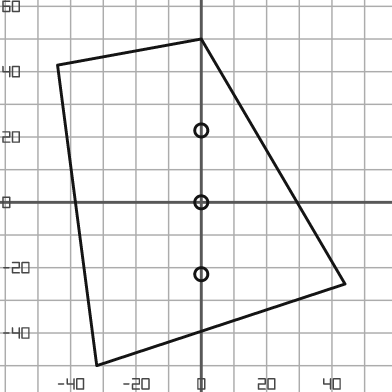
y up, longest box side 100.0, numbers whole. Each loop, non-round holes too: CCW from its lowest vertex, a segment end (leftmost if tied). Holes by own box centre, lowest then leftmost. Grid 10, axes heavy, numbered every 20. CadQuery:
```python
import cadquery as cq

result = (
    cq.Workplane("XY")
    .moveTo(-32.0, -50.0)
    .lineTo(44.0, -25.0)
    .lineTo(0.0, 50.0)
    .lineTo(-44.0, 42.0)
    .close()
    .moveTo(0.0, -22.0)
    .circle(2.0)
    .moveTo(0.0, 0.0)
    .circle(2.0)
    .moveTo(0.0, 22.0)
    .circle(2.0)
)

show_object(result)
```